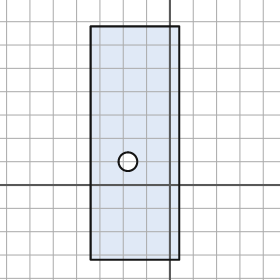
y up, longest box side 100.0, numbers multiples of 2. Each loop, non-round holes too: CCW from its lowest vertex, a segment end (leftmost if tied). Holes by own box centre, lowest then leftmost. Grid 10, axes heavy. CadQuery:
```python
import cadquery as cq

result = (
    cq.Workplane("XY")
    .moveTo(-34.0, -32.0)
    .lineTo(4.0, -32.0)
    .lineTo(4.0, 68.0)
    .lineTo(-34.0, 68.0)
    .close()
    .moveTo(-18.0, 10.0)
    .circle(4.0)
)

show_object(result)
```